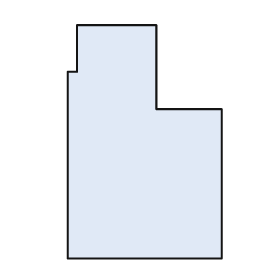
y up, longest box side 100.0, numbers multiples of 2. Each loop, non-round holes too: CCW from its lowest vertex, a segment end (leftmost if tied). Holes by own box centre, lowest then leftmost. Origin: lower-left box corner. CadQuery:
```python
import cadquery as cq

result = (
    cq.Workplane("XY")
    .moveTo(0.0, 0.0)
    .lineTo(66.0, 0.0)
    .lineTo(66.0, 64.0)
    .lineTo(38.0, 64.0)
    .lineTo(38.0, 100.0)
    .lineTo(4.0, 100.0)
    .lineTo(4.0, 80.0)
    .lineTo(0.0, 80.0)
    .close()
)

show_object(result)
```